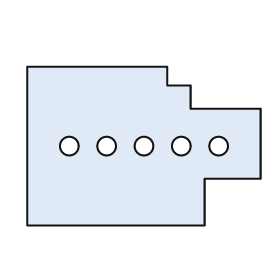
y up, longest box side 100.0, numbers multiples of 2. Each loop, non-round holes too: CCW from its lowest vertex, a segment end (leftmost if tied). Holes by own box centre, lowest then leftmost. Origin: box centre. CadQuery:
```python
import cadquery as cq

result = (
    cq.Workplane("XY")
    .moveTo(-50.0, -34.0)
    .lineTo(26.0, -34.0)
    .lineTo(26.0, -14.0)
    .lineTo(50.0, -14.0)
    .lineTo(50.0, 16.0)
    .lineTo(20.0, 16.0)
    .lineTo(20.0, 26.0)
    .lineTo(10.0, 26.0)
    .lineTo(10.0, 34.0)
    .lineTo(-50.0, 34.0)
    .close()
    .moveTo(-32.0, 0.0)
    .circle(4.0)
    .moveTo(-16.0, 0.0)
    .circle(4.0)
    .moveTo(0.0, 0.0)
    .circle(4.0)
    .moveTo(16.0, 0.0)
    .circle(4.0)
    .moveTo(32.0, 0.0)
    .circle(4.0)
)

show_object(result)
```